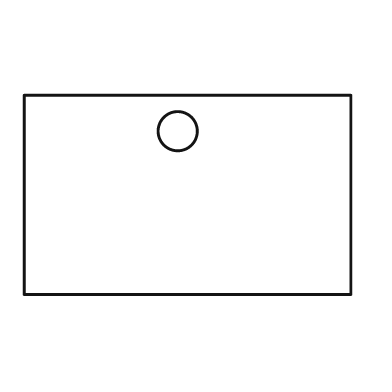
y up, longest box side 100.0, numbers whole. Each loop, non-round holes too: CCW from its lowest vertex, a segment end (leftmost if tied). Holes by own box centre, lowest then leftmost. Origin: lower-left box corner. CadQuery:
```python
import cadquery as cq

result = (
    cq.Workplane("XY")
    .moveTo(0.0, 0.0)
    .lineTo(100.0, 0.0)
    .lineTo(100.0, 61.0)
    .lineTo(0.0, 61.0)
    .close()
    .moveTo(47.0, 50.0)
    .circle(6.0)
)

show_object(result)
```